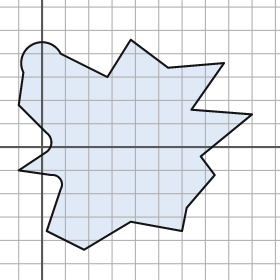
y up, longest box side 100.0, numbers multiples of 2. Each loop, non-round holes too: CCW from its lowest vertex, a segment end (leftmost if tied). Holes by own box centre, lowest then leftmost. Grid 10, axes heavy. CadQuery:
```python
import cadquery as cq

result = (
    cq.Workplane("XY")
    .moveTo(18.0, -44.0)
    .lineTo(38.0, -32.0)
    .lineTo(60.0, -36.0)
    .lineTo(62.0, -26.0)
    .lineTo(74.0, -12.0)
    .lineTo(68.0, -4.0)
    .lineTo(90.0, 14.0)
    .lineTo(64.0, 16.0)
    .lineTo(78.0, 36.0)
    .lineTo(54.0, 34.0)
    .lineTo(38.0, 46.0)
    .lineTo(28.0, 30.0)
    .lineTo(8.0, 40.0)
    .threePointArc((-4.0, 44.0), (-8.0, 32.0))
    .lineTo(-10.0, 18.0)
    .lineTo(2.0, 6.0)
    .threePointArc((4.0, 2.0), (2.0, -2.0))
    .lineTo(-10.0, -10.0)
    .lineTo(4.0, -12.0)
    .threePointArc((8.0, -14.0), (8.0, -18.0))
    .lineTo(2.0, -36.0)
    .close()
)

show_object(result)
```